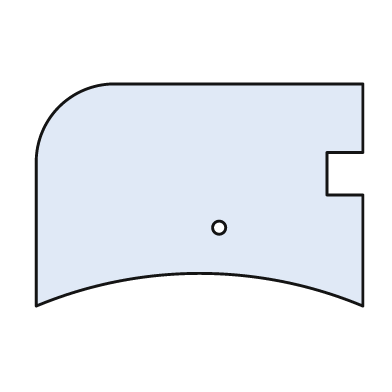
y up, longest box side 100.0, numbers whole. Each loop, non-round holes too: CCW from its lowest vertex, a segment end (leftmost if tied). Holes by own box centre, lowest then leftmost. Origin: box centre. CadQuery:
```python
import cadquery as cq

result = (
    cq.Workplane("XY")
    .moveTo(-50.0, -34.0)
    .threePointArc((0.0, -24.0), (50.0, -34.0))
    .lineTo(50.0, 0.0)
    .lineTo(39.0, 0.0)
    .lineTo(39.0, 13.0)
    .lineTo(50.0, 13.0)
    .lineTo(50.0, 34.0)
    .lineTo(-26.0, 34.0)
    .threePointArc((-43.0, 27.0), (-50.0, 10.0))
    .close()
    .moveTo(6.0, -10.0)
    .circle(2.0)
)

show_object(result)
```